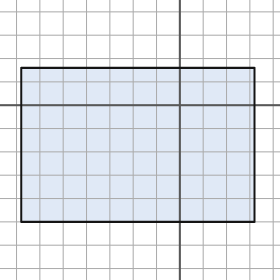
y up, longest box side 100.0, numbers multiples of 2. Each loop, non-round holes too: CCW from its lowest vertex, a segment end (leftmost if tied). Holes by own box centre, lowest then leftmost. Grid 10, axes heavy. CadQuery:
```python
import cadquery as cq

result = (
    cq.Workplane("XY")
    .moveTo(-68.0, -50.0)
    .lineTo(32.0, -50.0)
    .lineTo(32.0, 16.0)
    .lineTo(-68.0, 16.0)
    .close()
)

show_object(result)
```